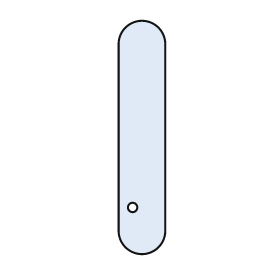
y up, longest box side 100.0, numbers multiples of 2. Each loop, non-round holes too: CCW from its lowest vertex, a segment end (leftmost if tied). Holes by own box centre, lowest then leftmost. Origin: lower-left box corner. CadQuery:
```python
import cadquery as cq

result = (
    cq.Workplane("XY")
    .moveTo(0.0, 10.0)
    .threePointArc((10.0, 0.0), (20.0, 10.0))
    .lineTo(20.0, 90.0)
    .threePointArc((10.0, 100.0), (0.0, 90.0))
    .close()
    .moveTo(6.0, 20.0)
    .circle(2.0)
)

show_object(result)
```